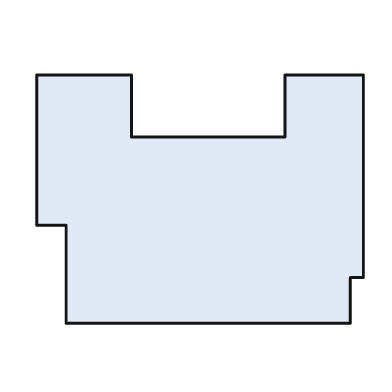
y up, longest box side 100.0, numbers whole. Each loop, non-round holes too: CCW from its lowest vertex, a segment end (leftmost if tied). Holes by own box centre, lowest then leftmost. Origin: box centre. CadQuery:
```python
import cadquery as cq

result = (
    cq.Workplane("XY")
    .moveTo(-41.0, -38.0)
    .lineTo(46.0, -38.0)
    .lineTo(46.0, -24.0)
    .lineTo(50.0, -24.0)
    .lineTo(50.0, 38.0)
    .lineTo(26.0, 38.0)
    .lineTo(26.0, 19.0)
    .lineTo(-21.0, 19.0)
    .lineTo(-21.0, 38.0)
    .lineTo(-50.0, 38.0)
    .lineTo(-50.0, -8.0)
    .lineTo(-41.0, -8.0)
    .close()
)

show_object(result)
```